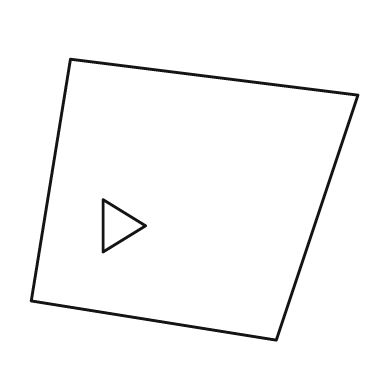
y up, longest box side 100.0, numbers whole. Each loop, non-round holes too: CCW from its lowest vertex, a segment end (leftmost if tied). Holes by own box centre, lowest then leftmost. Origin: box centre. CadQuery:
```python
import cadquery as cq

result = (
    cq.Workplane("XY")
    .moveTo(25.0, -43.0)
    .lineTo(50.0, 32.0)
    .lineTo(-38.0, 43.0)
    .lineTo(-50.0, -31.0)
    .close()
    .moveTo(-28.0, -16.0)
    .lineTo(-15.0, -8.0)
    .lineTo(-28.0, 0.0)
    .close()
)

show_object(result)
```